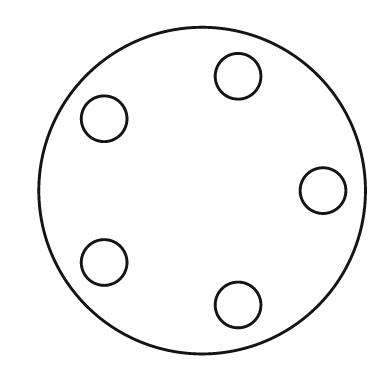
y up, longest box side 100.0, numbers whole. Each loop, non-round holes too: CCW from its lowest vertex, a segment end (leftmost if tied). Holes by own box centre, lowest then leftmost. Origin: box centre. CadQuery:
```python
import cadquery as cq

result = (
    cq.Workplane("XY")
    .moveTo(0.0, 0.0)
    .circle(50.0)
    .moveTo(11.0, -35.0)
    .circle(7.0)
    .moveTo(-30.0, -22.0)
    .circle(7.0)
    .moveTo(37.0, 0.0)
    .circle(7.0)
    .moveTo(-30.0, 22.0)
    .circle(7.0)
    .moveTo(11.0, 35.0)
    .circle(7.0)
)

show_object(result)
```